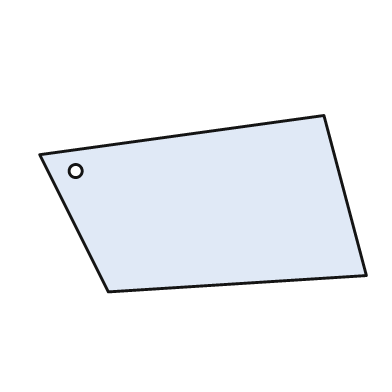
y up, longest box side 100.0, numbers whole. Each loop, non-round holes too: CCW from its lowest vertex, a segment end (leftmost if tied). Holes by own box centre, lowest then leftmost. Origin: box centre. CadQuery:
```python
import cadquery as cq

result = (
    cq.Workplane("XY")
    .moveTo(-29.0, -27.0)
    .lineTo(50.0, -22.0)
    .lineTo(37.0, 27.0)
    .lineTo(-50.0, 15.0)
    .close()
    .moveTo(-39.0, 10.0)
    .circle(2.0)
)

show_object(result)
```